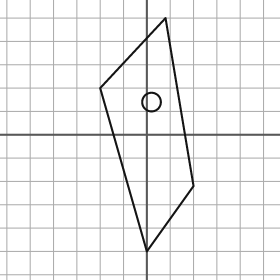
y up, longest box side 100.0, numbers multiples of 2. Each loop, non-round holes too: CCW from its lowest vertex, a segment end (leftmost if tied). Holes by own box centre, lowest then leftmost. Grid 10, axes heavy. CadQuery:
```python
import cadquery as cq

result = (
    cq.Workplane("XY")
    .moveTo(0.0, -50.0)
    .lineTo(20.0, -22.0)
    .lineTo(8.0, 50.0)
    .lineTo(-20.0, 20.0)
    .close()
    .moveTo(2.0, 14.0)
    .circle(4.0)
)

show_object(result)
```